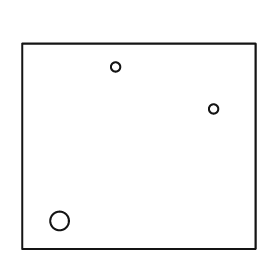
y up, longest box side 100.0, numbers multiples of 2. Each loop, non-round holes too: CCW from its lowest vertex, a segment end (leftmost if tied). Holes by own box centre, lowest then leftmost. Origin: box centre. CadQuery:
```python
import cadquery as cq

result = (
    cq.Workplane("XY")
    .moveTo(-50.0, -44.0)
    .lineTo(50.0, -44.0)
    .lineTo(50.0, 44.0)
    .lineTo(-50.0, 44.0)
    .close()
    .moveTo(-34.0, -32.0)
    .circle(4.0)
    .moveTo(32.0, 16.0)
    .circle(2.0)
    .moveTo(-10.0, 34.0)
    .circle(2.0)
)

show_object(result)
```